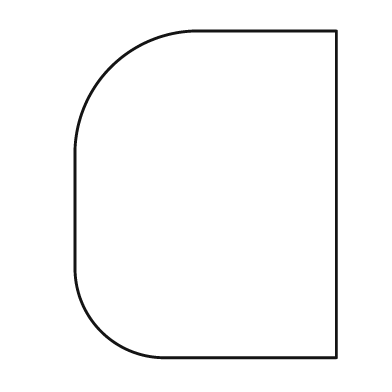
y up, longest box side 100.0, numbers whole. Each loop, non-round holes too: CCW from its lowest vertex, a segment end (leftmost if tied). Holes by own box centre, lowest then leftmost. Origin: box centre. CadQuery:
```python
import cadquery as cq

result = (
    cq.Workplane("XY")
    .moveTo(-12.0, -50.0)
    .lineTo(40.0, -50.0)
    .lineTo(40.0, 50.0)
    .lineTo(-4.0, 50.0)
    .threePointArc((-29.0, 39.0), (-40.0, 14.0))
    .lineTo(-40.0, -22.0)
    .threePointArc((-32.0, -42.0), (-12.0, -50.0))
    .close()
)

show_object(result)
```